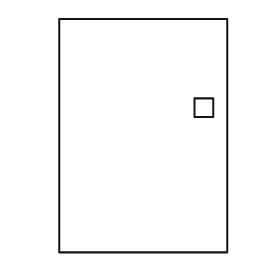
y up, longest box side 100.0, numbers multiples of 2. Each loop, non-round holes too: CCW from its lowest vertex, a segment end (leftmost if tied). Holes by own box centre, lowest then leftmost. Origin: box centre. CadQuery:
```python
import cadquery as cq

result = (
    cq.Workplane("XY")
    .moveTo(-36.0, -50.0)
    .lineTo(36.0, -50.0)
    .lineTo(36.0, 50.0)
    .lineTo(-36.0, 50.0)
    .close()
    .moveTo(22.0, 8.0)
    .lineTo(30.0, 8.0)
    .lineTo(30.0, 16.0)
    .lineTo(22.0, 16.0)
    .close()
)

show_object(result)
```